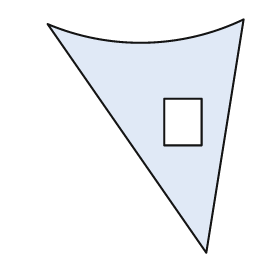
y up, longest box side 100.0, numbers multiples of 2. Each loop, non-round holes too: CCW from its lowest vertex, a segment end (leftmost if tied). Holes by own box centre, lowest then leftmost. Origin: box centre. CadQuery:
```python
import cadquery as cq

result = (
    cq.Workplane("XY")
    .moveTo(26.0, -50.0)
    .lineTo(42.0, 50.0)
    .threePointArc((0.0, 40.0), (-42.0, 48.0))
    .close()
    .moveTo(8.0, -4.0)
    .lineTo(24.0, -4.0)
    .lineTo(24.0, 16.0)
    .lineTo(8.0, 16.0)
    .close()
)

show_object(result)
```